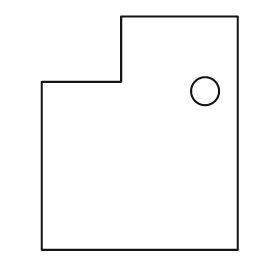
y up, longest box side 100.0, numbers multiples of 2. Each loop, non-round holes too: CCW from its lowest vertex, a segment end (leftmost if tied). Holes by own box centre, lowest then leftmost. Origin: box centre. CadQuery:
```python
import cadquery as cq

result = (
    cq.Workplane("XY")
    .moveTo(-42.0, -50.0)
    .lineTo(42.0, -50.0)
    .lineTo(42.0, 50.0)
    .lineTo(-8.0, 50.0)
    .lineTo(-8.0, 22.0)
    .lineTo(-42.0, 22.0)
    .close()
    .moveTo(28.0, 18.0)
    .circle(6.0)
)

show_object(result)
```